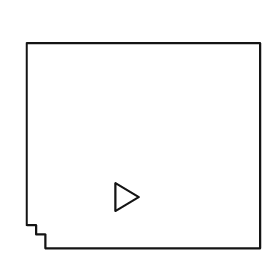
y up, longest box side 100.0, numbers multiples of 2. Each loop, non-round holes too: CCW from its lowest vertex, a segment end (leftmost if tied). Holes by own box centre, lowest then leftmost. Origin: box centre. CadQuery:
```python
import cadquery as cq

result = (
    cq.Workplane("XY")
    .moveTo(-42.0, -44.0)
    .lineTo(50.0, -44.0)
    .lineTo(50.0, 44.0)
    .lineTo(-50.0, 44.0)
    .lineTo(-50.0, -34.0)
    .lineTo(-46.0, -34.0)
    .lineTo(-46.0, -38.0)
    .lineTo(-42.0, -38.0)
    .close()
    .moveTo(-12.0, -28.0)
    .lineTo(-2.0, -22.0)
    .lineTo(-12.0, -16.0)
    .close()
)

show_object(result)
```